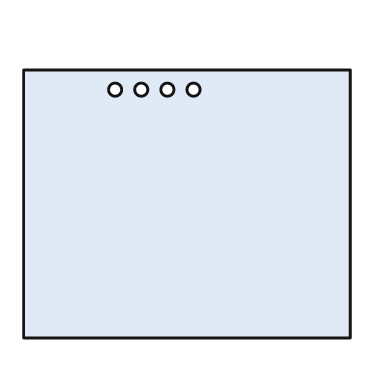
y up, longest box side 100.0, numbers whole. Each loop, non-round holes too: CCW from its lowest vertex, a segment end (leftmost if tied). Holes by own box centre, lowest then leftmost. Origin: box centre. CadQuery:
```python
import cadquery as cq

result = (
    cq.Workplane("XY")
    .moveTo(-50.0, -41.0)
    .lineTo(50.0, -41.0)
    .lineTo(50.0, 41.0)
    .lineTo(-50.0, 41.0)
    .close()
    .moveTo(-22.0, 35.0)
    .circle(2.0)
    .moveTo(-14.0, 35.0)
    .circle(2.0)
    .moveTo(-6.0, 35.0)
    .circle(2.0)
    .moveTo(2.0, 35.0)
    .circle(2.0)
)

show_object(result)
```